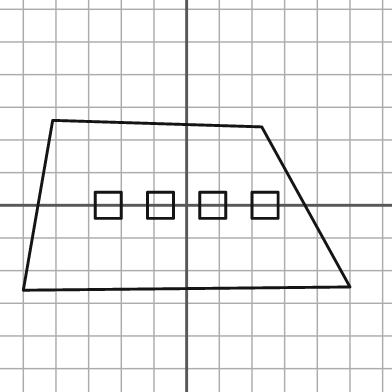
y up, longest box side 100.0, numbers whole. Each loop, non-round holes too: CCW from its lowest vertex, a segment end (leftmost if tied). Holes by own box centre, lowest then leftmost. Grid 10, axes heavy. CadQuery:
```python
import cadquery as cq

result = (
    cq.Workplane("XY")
    .moveTo(-50.0, -26.0)
    .lineTo(50.0, -25.0)
    .lineTo(23.0, 24.0)
    .lineTo(-41.0, 26.0)
    .close()
    .moveTo(-28.0, -4.0)
    .lineTo(-20.0, -4.0)
    .lineTo(-20.0, 4.0)
    .lineTo(-28.0, 4.0)
    .close()
    .moveTo(-12.0, -4.0)
    .lineTo(-4.0, -4.0)
    .lineTo(-4.0, 4.0)
    .lineTo(-12.0, 4.0)
    .close()
    .moveTo(4.0, -4.0)
    .lineTo(12.0, -4.0)
    .lineTo(12.0, 4.0)
    .lineTo(4.0, 4.0)
    .close()
    .moveTo(20.0, -4.0)
    .lineTo(28.0, -4.0)
    .lineTo(28.0, 4.0)
    .lineTo(20.0, 4.0)
    .close()
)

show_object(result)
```